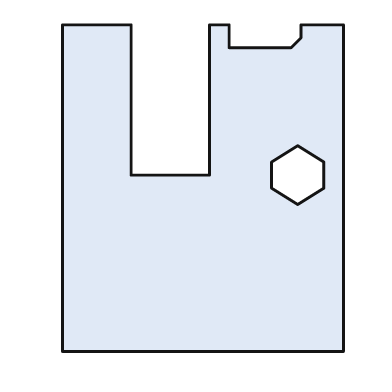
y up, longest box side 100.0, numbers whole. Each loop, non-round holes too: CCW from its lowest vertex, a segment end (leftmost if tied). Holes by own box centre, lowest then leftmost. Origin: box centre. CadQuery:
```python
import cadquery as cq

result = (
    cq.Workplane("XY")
    .moveTo(-43.0, -50.0)
    .lineTo(43.0, -50.0)
    .lineTo(43.0, 50.0)
    .lineTo(30.0, 50.0)
    .lineTo(30.0, 46.0)
    .lineTo(27.0, 43.0)
    .lineTo(8.0, 43.0)
    .lineTo(8.0, 50.0)
    .lineTo(2.0, 50.0)
    .lineTo(2.0, 4.0)
    .lineTo(-22.0, 4.0)
    .lineTo(-22.0, 50.0)
    .lineTo(-43.0, 50.0)
    .close()
    .moveTo(29.0, -5.0)
    .lineTo(37.0, 0.0)
    .lineTo(37.0, 8.0)
    .lineTo(29.0, 13.0)
    .lineTo(21.0, 8.0)
    .lineTo(21.0, 0.0)
    .close()
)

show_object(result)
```